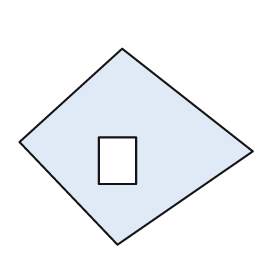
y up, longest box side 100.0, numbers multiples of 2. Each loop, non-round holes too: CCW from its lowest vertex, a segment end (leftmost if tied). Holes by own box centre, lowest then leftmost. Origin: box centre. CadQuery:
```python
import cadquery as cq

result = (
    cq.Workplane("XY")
    .moveTo(-8.0, -42.0)
    .lineTo(50.0, -2.0)
    .lineTo(-6.0, 42.0)
    .lineTo(-50.0, 2.0)
    .close()
    .moveTo(-16.0, -16.0)
    .lineTo(0.0, -16.0)
    .lineTo(0.0, 4.0)
    .lineTo(-16.0, 4.0)
    .close()
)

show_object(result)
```